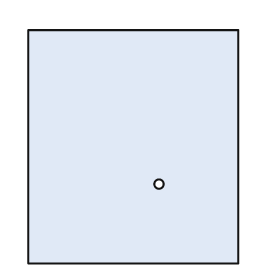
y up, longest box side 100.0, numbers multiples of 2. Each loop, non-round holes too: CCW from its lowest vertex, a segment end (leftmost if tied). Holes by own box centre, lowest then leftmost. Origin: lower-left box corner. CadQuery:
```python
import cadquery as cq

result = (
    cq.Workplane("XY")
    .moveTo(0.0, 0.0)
    .lineTo(90.0, 0.0)
    .lineTo(90.0, 100.0)
    .lineTo(0.0, 100.0)
    .close()
    .moveTo(56.0, 34.0)
    .circle(2.0)
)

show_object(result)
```